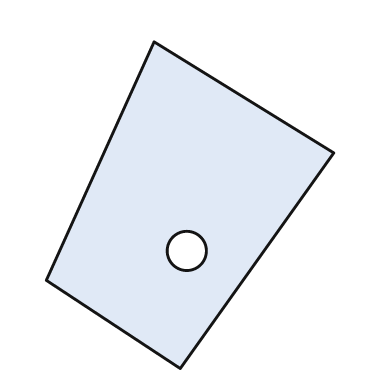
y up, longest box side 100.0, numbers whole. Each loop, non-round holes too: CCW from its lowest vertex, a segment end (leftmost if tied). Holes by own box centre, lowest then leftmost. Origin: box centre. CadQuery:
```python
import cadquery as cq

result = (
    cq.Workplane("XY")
    .moveTo(-3.0, -50.0)
    .lineTo(44.0, 16.0)
    .lineTo(-11.0, 50.0)
    .lineTo(-44.0, -23.0)
    .close()
    .moveTo(-1.0, -14.0)
    .circle(6.0)
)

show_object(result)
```